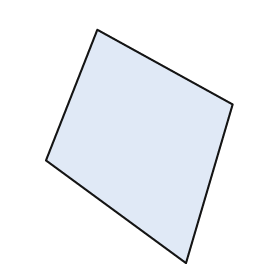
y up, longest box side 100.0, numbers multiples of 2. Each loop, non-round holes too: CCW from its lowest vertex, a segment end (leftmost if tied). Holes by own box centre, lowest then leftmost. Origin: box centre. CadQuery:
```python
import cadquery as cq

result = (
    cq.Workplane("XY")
    .moveTo(20.0, -50.0)
    .lineTo(40.0, 18.0)
    .lineTo(-18.0, 50.0)
    .lineTo(-40.0, -6.0)
    .close()
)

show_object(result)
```